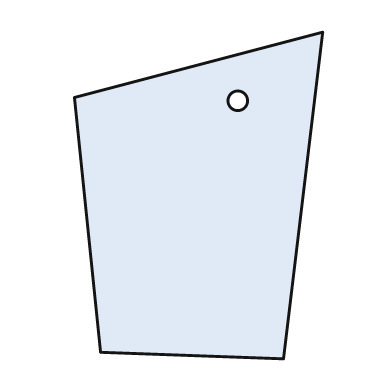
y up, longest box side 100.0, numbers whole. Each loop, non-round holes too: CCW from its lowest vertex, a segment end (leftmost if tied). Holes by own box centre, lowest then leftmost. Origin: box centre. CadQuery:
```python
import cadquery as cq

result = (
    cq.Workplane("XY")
    .moveTo(26.0, -50.0)
    .lineTo(38.0, 50.0)
    .lineTo(-38.0, 30.0)
    .lineTo(-30.0, -48.0)
    .close()
    .moveTo(12.0, 29.0)
    .circle(3.0)
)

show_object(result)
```